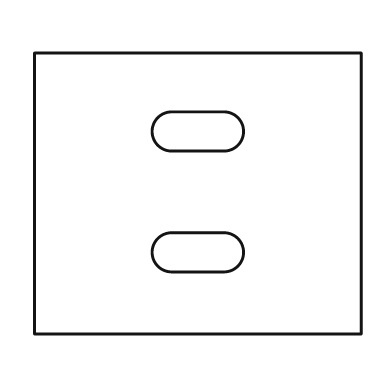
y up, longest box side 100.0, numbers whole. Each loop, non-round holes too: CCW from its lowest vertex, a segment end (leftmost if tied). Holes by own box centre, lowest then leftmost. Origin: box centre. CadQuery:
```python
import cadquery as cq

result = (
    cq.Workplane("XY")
    .moveTo(-50.0, -43.0)
    .lineTo(50.0, -43.0)
    .lineTo(50.0, 43.0)
    .lineTo(-50.0, 43.0)
    .close()
    .moveTo(-8.0, -24.0)
    .lineTo(8.0, -24.0)
    .threePointArc((14.0, -18.0), (8.0, -12.0))
    .lineTo(-8.0, -12.0)
    .threePointArc((-14.0, -18.0), (-8.0, -24.0))
    .close()
    .moveTo(-8.0, 13.0)
    .lineTo(8.0, 13.0)
    .threePointArc((14.0, 19.0), (8.0, 25.0))
    .lineTo(-8.0, 25.0)
    .threePointArc((-14.0, 19.0), (-8.0, 13.0))
    .close()
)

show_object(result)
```